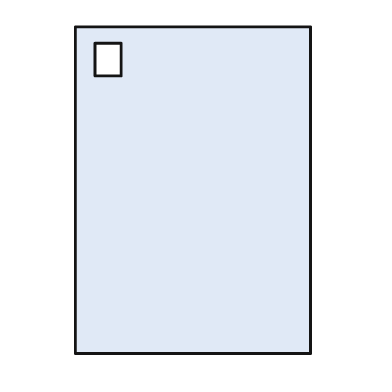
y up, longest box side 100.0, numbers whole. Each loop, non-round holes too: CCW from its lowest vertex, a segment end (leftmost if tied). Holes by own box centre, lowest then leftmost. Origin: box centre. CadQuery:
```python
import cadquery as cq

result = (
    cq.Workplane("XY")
    .moveTo(-36.0, -50.0)
    .lineTo(36.0, -50.0)
    .lineTo(36.0, 50.0)
    .lineTo(-36.0, 50.0)
    .close()
    .moveTo(-30.0, 35.0)
    .lineTo(-22.0, 35.0)
    .lineTo(-22.0, 45.0)
    .lineTo(-30.0, 45.0)
    .close()
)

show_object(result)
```